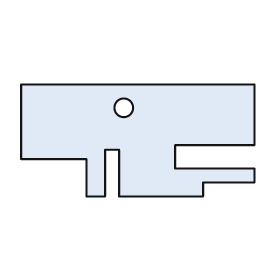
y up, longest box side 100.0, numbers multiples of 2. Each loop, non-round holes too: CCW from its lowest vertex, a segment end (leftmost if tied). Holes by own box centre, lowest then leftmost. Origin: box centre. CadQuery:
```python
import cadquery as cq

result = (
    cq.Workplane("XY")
    .moveTo(-22.0, -24.0)
    .lineTo(-14.0, -24.0)
    .lineTo(-14.0, -4.0)
    .lineTo(-8.0, -4.0)
    .lineTo(-8.0, -24.0)
    .lineTo(28.0, -24.0)
    .lineTo(28.0, -18.0)
    .lineTo(50.0, -18.0)
    .lineTo(50.0, -12.0)
    .lineTo(16.0, -12.0)
    .lineTo(16.0, -2.0)
    .lineTo(50.0, -2.0)
    .lineTo(50.0, 24.0)
    .lineTo(-50.0, 24.0)
    .lineTo(-50.0, -8.0)
    .lineTo(-22.0, -8.0)
    .close()
    .moveTo(-6.0, 14.0)
    .circle(4.0)
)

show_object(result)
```